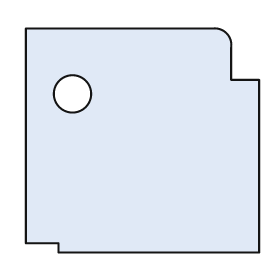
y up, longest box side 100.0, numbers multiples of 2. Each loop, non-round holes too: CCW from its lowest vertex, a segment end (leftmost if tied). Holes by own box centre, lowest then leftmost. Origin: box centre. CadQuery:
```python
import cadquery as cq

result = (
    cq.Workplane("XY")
    .moveTo(-36.0, -48.0)
    .lineTo(50.0, -48.0)
    .lineTo(50.0, 26.0)
    .lineTo(38.0, 26.0)
    .lineTo(38.0, 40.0)
    .threePointArc((36.0, 46.0), (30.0, 48.0))
    .lineTo(-50.0, 48.0)
    .lineTo(-50.0, -44.0)
    .lineTo(-36.0, -44.0)
    .close()
    .moveTo(-30.0, 20.0)
    .circle(8.0)
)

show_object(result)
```